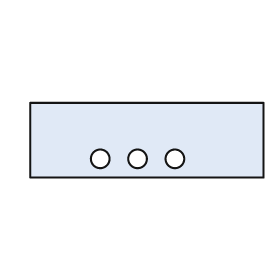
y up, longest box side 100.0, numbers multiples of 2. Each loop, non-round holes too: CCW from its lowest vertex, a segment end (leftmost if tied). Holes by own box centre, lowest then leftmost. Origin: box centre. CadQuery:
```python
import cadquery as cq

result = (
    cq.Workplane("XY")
    .moveTo(-50.0, -16.0)
    .lineTo(50.0, -16.0)
    .lineTo(50.0, 16.0)
    .lineTo(-50.0, 16.0)
    .close()
    .moveTo(-20.0, -8.0)
    .circle(4.0)
    .moveTo(-4.0, -8.0)
    .circle(4.0)
    .moveTo(12.0, -8.0)
    .circle(4.0)
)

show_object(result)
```